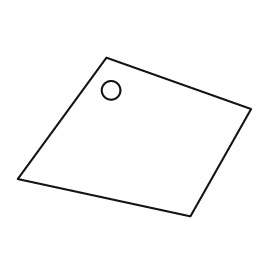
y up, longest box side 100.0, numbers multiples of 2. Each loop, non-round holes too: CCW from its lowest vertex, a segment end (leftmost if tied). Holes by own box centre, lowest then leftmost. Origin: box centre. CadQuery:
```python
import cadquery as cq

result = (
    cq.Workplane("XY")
    .moveTo(24.0, -34.0)
    .lineTo(50.0, 12.0)
    .lineTo(-12.0, 34.0)
    .lineTo(-50.0, -18.0)
    .close()
    .moveTo(-10.0, 20.0)
    .circle(4.0)
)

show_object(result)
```